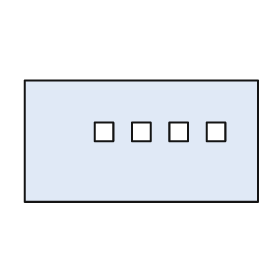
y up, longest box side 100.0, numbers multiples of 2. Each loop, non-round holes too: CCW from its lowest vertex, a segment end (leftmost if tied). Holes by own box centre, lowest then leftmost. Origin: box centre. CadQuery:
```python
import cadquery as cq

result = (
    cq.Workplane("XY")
    .moveTo(-50.0, -26.0)
    .lineTo(50.0, -26.0)
    .lineTo(50.0, 26.0)
    .lineTo(-50.0, 26.0)
    .close()
    .moveTo(-20.0, 0.0)
    .lineTo(-12.0, 0.0)
    .lineTo(-12.0, 8.0)
    .lineTo(-20.0, 8.0)
    .close()
    .moveTo(-4.0, 0.0)
    .lineTo(4.0, 0.0)
    .lineTo(4.0, 8.0)
    .lineTo(-4.0, 8.0)
    .close()
    .moveTo(12.0, 0.0)
    .lineTo(20.0, 0.0)
    .lineTo(20.0, 8.0)
    .lineTo(12.0, 8.0)
    .close()
    .moveTo(28.0, 0.0)
    .lineTo(36.0, 0.0)
    .lineTo(36.0, 8.0)
    .lineTo(28.0, 8.0)
    .close()
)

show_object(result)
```